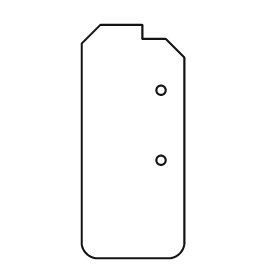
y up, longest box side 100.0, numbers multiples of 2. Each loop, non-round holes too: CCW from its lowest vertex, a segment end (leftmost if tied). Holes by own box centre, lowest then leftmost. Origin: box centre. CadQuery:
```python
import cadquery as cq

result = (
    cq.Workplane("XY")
    .moveTo(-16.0, -50.0)
    .lineTo(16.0, -50.0)
    .threePointArc((20.0, -48.0), (22.0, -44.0))
    .lineTo(22.0, 36.0)
    .lineTo(14.0, 44.0)
    .lineTo(4.0, 44.0)
    .lineTo(4.0, 50.0)
    .lineTo(-14.0, 50.0)
    .lineTo(-22.0, 42.0)
    .lineTo(-22.0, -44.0)
    .threePointArc((-20.0, -48.0), (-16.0, -50.0))
    .close()
    .moveTo(12.0, -8.0)
    .circle(2.0)
    .moveTo(12.0, 22.0)
    .circle(2.0)
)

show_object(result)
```